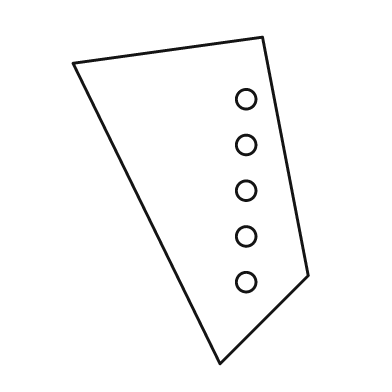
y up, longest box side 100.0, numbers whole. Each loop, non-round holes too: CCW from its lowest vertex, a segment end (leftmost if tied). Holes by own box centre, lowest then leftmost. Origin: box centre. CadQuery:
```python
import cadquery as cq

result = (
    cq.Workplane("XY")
    .moveTo(9.0, -50.0)
    .lineTo(36.0, -23.0)
    .lineTo(22.0, 50.0)
    .lineTo(-36.0, 42.0)
    .close()
    .moveTo(17.0, -25.0)
    .circle(3.0)
    .moveTo(17.0, -11.0)
    .circle(3.0)
    .moveTo(17.0, 3.0)
    .circle(3.0)
    .moveTo(17.0, 17.0)
    .circle(3.0)
    .moveTo(17.0, 31.0)
    .circle(3.0)
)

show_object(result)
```